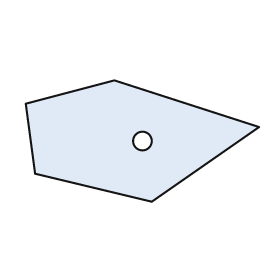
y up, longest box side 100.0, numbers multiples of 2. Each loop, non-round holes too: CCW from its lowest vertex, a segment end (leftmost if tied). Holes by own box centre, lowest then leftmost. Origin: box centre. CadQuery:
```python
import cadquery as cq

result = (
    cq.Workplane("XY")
    .moveTo(4.0, -26.0)
    .lineTo(50.0, 6.0)
    .lineTo(-12.0, 26.0)
    .lineTo(-50.0, 16.0)
    .lineTo(-46.0, -14.0)
    .close()
    .moveTo(0.0, 0.0)
    .circle(4.0)
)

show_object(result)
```